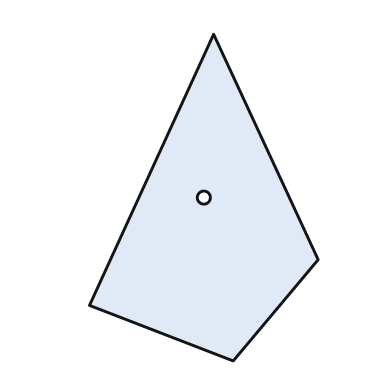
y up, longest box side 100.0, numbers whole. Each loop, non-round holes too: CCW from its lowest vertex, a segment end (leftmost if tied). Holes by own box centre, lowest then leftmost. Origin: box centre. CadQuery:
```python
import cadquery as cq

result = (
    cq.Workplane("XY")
    .moveTo(9.0, -50.0)
    .lineTo(35.0, -19.0)
    .lineTo(3.0, 50.0)
    .lineTo(-35.0, -33.0)
    .close()
    .moveTo(0.0, 0.0)
    .circle(2.0)
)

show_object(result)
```